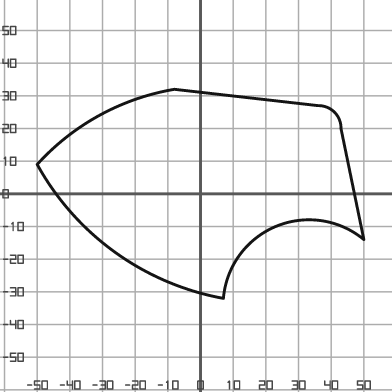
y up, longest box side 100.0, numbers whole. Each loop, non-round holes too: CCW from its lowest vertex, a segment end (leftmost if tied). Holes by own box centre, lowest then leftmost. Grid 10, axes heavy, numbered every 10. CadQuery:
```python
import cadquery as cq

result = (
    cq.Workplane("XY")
    .moveTo(7.0, -32.0)
    .threePointArc((23.0, -10.0), (50.0, -14.0))
    .lineTo(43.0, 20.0)
    .threePointArc((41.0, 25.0), (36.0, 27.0))
    .lineTo(-8.0, 32.0)
    .threePointArc((-31.0, 24.0), (-50.0, 9.0))
    .threePointArc((-26.0, -18.0), (7.0, -32.0))
    .close()
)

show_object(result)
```